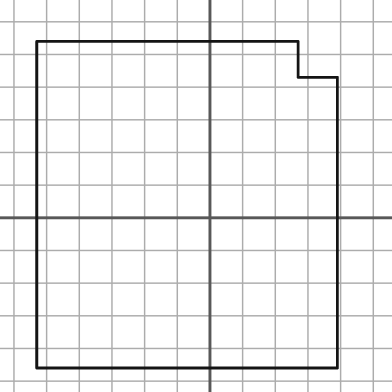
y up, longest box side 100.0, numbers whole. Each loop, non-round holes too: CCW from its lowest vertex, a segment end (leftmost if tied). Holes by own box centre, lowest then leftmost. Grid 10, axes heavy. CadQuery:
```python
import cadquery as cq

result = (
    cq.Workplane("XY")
    .moveTo(-53.0, -46.0)
    .lineTo(39.0, -46.0)
    .lineTo(39.0, 43.0)
    .lineTo(27.0, 43.0)
    .lineTo(27.0, 54.0)
    .lineTo(-53.0, 54.0)
    .close()
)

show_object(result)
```